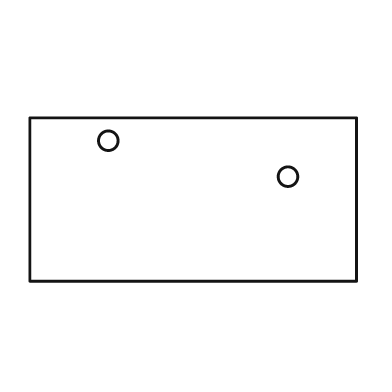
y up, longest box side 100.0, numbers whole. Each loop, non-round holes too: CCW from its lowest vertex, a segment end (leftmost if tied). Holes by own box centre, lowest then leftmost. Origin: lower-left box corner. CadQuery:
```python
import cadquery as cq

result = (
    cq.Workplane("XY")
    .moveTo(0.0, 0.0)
    .lineTo(100.0, 0.0)
    .lineTo(100.0, 50.0)
    .lineTo(0.0, 50.0)
    .close()
    .moveTo(79.0, 32.0)
    .circle(3.0)
    .moveTo(24.0, 43.0)
    .circle(3.0)
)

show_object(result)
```